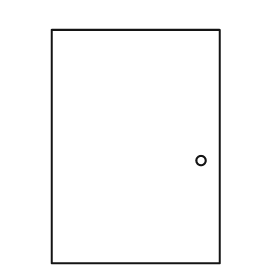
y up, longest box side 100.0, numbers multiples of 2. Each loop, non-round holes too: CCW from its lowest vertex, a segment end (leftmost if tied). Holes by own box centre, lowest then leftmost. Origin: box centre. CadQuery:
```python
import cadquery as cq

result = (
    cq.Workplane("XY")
    .moveTo(-36.0, -50.0)
    .lineTo(36.0, -50.0)
    .lineTo(36.0, 50.0)
    .lineTo(-36.0, 50.0)
    .close()
    .moveTo(28.0, -6.0)
    .circle(2.0)
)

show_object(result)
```